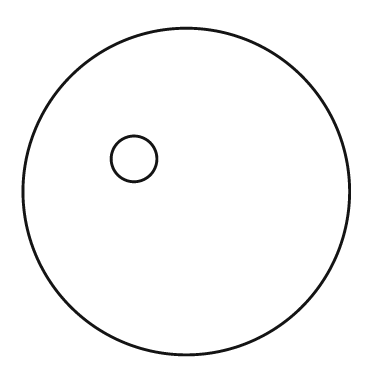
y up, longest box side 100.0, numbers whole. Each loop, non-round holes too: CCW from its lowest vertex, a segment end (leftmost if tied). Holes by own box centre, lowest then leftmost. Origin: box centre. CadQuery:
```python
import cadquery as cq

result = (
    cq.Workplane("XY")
    .moveTo(0.0, 0.0)
    .circle(50.0)
    .moveTo(-16.0, 10.0)
    .circle(7.0)
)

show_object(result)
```